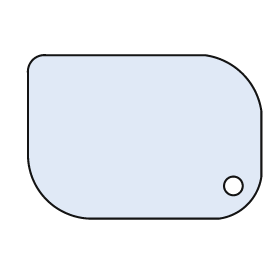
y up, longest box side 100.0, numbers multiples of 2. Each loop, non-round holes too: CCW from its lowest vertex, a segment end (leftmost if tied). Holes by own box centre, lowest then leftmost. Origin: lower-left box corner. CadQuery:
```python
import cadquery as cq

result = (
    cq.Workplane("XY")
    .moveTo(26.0, 0.0)
    .lineTo(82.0, 0.0)
    .threePointArc((94.0, 6.0), (100.0, 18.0))
    .lineTo(100.0, 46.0)
    .threePointArc((92.0, 62.0), (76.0, 70.0))
    .lineTo(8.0, 70.0)
    .threePointArc((2.0, 68.0), (0.0, 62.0))
    .lineTo(0.0, 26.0)
    .threePointArc((8.0, 8.0), (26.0, 0.0))
    .close()
    .moveTo(88.0, 14.0)
    .circle(4.0)
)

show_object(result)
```